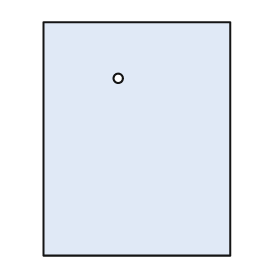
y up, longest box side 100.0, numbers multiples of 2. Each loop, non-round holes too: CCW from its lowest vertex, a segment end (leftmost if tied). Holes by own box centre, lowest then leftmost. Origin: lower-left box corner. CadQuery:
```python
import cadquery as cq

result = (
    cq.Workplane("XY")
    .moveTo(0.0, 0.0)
    .lineTo(80.0, 0.0)
    .lineTo(80.0, 100.0)
    .lineTo(0.0, 100.0)
    .close()
    .moveTo(32.0, 76.0)
    .circle(2.0)
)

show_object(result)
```